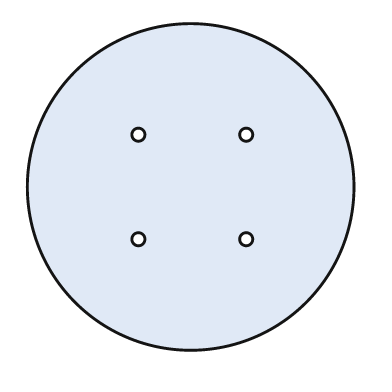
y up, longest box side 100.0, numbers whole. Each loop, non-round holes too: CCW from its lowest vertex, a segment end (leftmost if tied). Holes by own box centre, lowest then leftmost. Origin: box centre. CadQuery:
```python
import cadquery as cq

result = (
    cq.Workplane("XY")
    .moveTo(0.0, 0.0)
    .circle(50.0)
    .moveTo(-16.0, -16.0)
    .circle(2.0)
    .moveTo(17.0, -16.0)
    .circle(2.0)
    .moveTo(-16.0, 16.0)
    .circle(2.0)
    .moveTo(17.0, 16.0)
    .circle(2.0)
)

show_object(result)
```